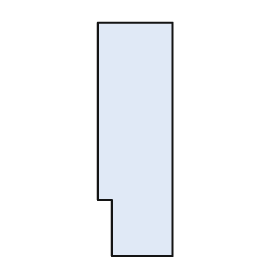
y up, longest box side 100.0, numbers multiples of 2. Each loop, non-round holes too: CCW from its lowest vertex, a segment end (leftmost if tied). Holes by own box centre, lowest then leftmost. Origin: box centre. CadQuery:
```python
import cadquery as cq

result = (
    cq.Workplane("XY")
    .moveTo(-10.0, -50.0)
    .lineTo(16.0, -50.0)
    .lineTo(16.0, 50.0)
    .lineTo(-16.0, 50.0)
    .lineTo(-16.0, -26.0)
    .lineTo(-10.0, -26.0)
    .close()
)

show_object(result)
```